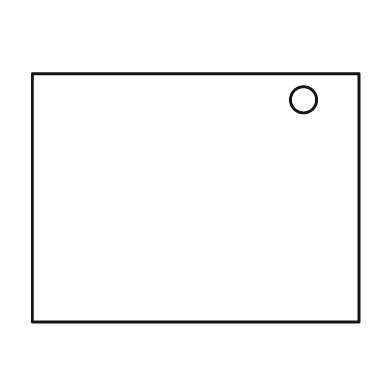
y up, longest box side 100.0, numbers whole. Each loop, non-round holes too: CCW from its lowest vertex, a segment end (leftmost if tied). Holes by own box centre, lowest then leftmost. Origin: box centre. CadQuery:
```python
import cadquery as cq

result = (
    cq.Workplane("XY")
    .moveTo(-50.0, -38.0)
    .lineTo(50.0, -38.0)
    .lineTo(50.0, 38.0)
    .lineTo(-50.0, 38.0)
    .close()
    .moveTo(33.0, 30.0)
    .circle(4.0)
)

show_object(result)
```